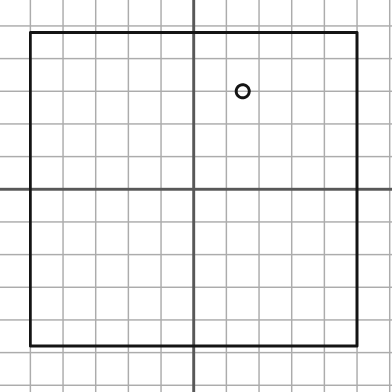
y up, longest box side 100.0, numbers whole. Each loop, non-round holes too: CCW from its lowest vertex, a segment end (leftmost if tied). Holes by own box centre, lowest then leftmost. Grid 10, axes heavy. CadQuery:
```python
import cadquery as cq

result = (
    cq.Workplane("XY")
    .moveTo(-50.0, -48.0)
    .lineTo(50.0, -48.0)
    .lineTo(50.0, 48.0)
    .lineTo(-50.0, 48.0)
    .close()
    .moveTo(15.0, 30.0)
    .circle(2.0)
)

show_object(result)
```